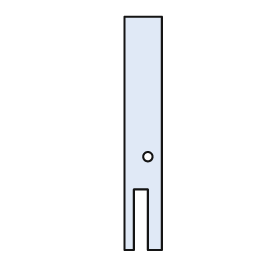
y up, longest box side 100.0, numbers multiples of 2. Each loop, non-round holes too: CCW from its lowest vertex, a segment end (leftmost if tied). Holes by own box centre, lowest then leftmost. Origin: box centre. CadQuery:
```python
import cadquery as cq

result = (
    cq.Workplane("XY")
    .moveTo(-8.0, -50.0)
    .lineTo(-4.0, -50.0)
    .lineTo(-4.0, -24.0)
    .lineTo(2.0, -24.0)
    .lineTo(2.0, -50.0)
    .lineTo(8.0, -50.0)
    .lineTo(8.0, 50.0)
    .lineTo(-8.0, 50.0)
    .close()
    .moveTo(2.0, -10.0)
    .circle(2.0)
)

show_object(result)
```